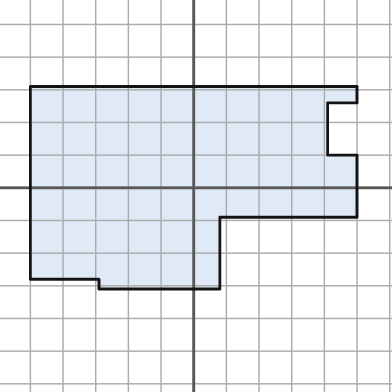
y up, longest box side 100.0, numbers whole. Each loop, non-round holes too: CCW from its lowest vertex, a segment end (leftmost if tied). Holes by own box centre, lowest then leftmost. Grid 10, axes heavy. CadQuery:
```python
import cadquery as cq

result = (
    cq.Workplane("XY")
    .moveTo(-29.0, -31.0)
    .lineTo(8.0, -31.0)
    .lineTo(8.0, -9.0)
    .lineTo(50.0, -9.0)
    .lineTo(50.0, 10.0)
    .lineTo(41.0, 10.0)
    .lineTo(41.0, 26.0)
    .lineTo(50.0, 26.0)
    .lineTo(50.0, 31.0)
    .lineTo(-50.0, 31.0)
    .lineTo(-50.0, -28.0)
    .lineTo(-29.0, -28.0)
    .close()
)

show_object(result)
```